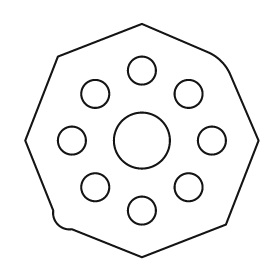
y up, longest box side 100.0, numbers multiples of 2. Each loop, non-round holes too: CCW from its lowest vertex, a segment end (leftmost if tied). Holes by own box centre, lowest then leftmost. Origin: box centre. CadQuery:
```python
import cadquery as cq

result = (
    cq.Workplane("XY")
    .moveTo(0.0, -50.0)
    .lineTo(36.0, -36.0)
    .lineTo(50.0, 0.0)
    .lineTo(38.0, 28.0)
    .threePointArc((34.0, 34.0), (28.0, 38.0))
    .lineTo(0.0, 50.0)
    .lineTo(-36.0, 36.0)
    .lineTo(-50.0, 0.0)
    .lineTo(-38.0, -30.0)
    .threePointArc((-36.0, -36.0), (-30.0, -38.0))
    .close()
    .moveTo(0.0, -30.0)
    .circle(6.0)
    .moveTo(-20.0, -20.0)
    .circle(6.0)
    .moveTo(20.0, -20.0)
    .circle(6.0)
    .moveTo(-30.0, 0.0)
    .circle(6.0)
    .moveTo(0.0, 0.0)
    .circle(12.0)
    .moveTo(30.0, 0.0)
    .circle(6.0)
    .moveTo(-20.0, 20.0)
    .circle(6.0)
    .moveTo(20.0, 20.0)
    .circle(6.0)
    .moveTo(0.0, 30.0)
    .circle(6.0)
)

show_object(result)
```